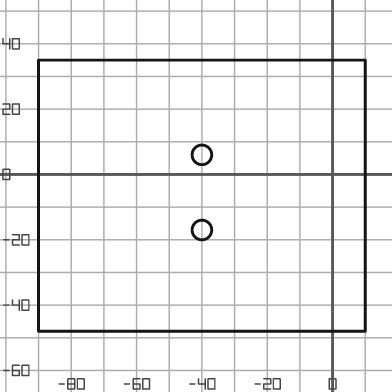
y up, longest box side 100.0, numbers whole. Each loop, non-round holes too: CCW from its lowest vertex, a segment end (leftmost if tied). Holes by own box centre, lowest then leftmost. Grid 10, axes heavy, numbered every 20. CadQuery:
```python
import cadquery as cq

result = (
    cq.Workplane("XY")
    .moveTo(-90.0, -48.0)
    .lineTo(10.0, -48.0)
    .lineTo(10.0, 35.0)
    .lineTo(-90.0, 35.0)
    .close()
    .moveTo(-40.0, -17.0)
    .circle(3.0)
    .moveTo(-40.0, 6.0)
    .circle(3.0)
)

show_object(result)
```